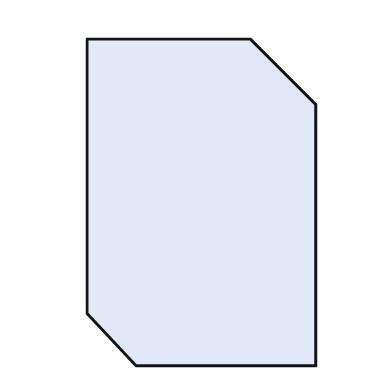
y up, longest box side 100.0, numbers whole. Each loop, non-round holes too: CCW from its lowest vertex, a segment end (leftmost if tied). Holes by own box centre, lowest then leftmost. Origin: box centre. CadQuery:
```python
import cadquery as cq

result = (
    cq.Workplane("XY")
    .moveTo(-20.0, -50.0)
    .lineTo(35.0, -50.0)
    .lineTo(35.0, 30.0)
    .lineTo(15.0, 50.0)
    .lineTo(-35.0, 50.0)
    .lineTo(-35.0, -34.0)
    .close()
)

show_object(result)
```